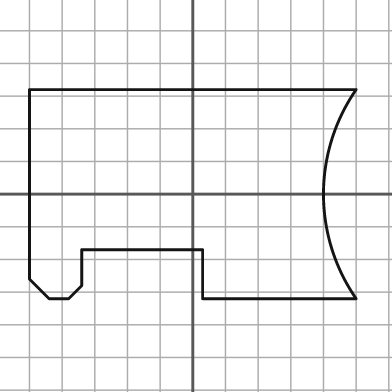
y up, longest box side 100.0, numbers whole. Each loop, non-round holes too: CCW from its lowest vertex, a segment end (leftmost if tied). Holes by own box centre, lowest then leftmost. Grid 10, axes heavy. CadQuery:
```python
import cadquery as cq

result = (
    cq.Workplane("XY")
    .moveTo(-44.0, -32.0)
    .lineTo(-38.0, -32.0)
    .lineTo(-34.0, -28.0)
    .lineTo(-34.0, -17.0)
    .lineTo(3.0, -17.0)
    .lineTo(3.0, -32.0)
    .lineTo(50.0, -32.0)
    .threePointArc((40.0, 0.0), (50.0, 32.0))
    .lineTo(-50.0, 32.0)
    .lineTo(-50.0, -26.0)
    .close()
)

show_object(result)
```